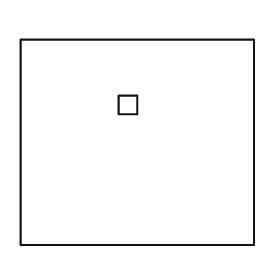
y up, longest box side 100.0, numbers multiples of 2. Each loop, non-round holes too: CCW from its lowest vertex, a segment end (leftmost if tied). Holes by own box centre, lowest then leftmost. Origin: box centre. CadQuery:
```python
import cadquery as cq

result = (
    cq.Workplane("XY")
    .moveTo(-50.0, -44.0)
    .lineTo(50.0, -44.0)
    .lineTo(50.0, 44.0)
    .lineTo(-50.0, 44.0)
    .close()
    .moveTo(-8.0, 12.0)
    .lineTo(0.0, 12.0)
    .lineTo(0.0, 20.0)
    .lineTo(-8.0, 20.0)
    .close()
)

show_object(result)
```